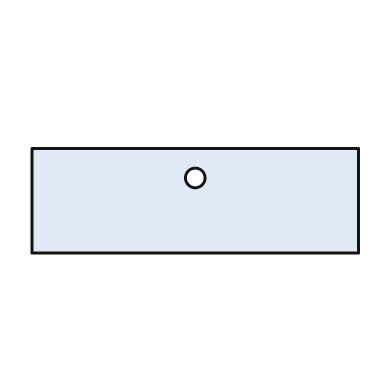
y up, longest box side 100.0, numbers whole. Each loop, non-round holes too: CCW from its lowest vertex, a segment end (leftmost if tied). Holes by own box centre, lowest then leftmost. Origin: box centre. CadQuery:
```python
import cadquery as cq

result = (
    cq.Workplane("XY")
    .moveTo(-50.0, -16.0)
    .lineTo(50.0, -16.0)
    .lineTo(50.0, 16.0)
    .lineTo(-50.0, 16.0)
    .close()
    .moveTo(0.0, 7.0)
    .circle(3.0)
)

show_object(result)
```